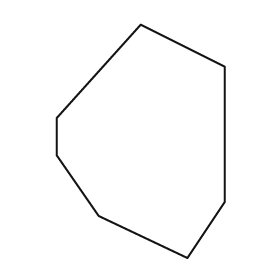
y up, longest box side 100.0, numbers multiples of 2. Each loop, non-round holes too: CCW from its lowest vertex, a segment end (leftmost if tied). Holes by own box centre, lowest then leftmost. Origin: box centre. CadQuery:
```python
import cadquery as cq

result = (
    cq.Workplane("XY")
    .moveTo(20.0, -50.0)
    .lineTo(36.0, -26.0)
    .lineTo(36.0, 32.0)
    .lineTo(0.0, 50.0)
    .lineTo(-36.0, 10.0)
    .lineTo(-36.0, -6.0)
    .lineTo(-18.0, -32.0)
    .close()
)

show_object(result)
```